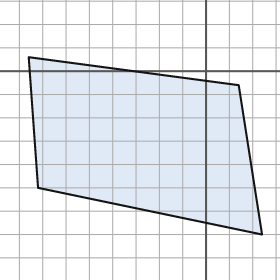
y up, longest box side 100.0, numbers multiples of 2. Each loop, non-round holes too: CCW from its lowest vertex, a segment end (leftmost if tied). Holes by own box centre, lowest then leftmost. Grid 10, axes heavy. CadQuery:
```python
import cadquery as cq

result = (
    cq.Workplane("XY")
    .moveTo(24.0, -70.0)
    .lineTo(14.0, -6.0)
    .lineTo(-76.0, 6.0)
    .lineTo(-72.0, -50.0)
    .close()
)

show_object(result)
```